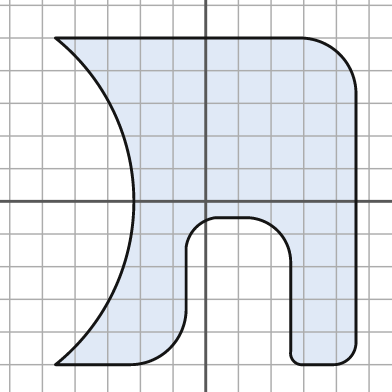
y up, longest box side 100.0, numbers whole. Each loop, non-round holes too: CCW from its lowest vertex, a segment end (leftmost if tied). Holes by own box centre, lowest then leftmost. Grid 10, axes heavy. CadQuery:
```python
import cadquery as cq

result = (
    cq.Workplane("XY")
    .moveTo(-46.0, -50.0)
    .lineTo(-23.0, -50.0)
    .threePointArc((-11.0, -45.0), (-6.0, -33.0))
    .lineTo(-6.0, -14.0)
    .threePointArc((-3.0, -8.0), (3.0, -5.0))
    .lineTo(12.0, -5.0)
    .threePointArc((22.0, -9.0), (26.0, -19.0))
    .lineTo(26.0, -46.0)
    .threePointArc((27.0, -49.0), (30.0, -50.0))
    .lineTo(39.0, -50.0)
    .threePointArc((44.0, -48.0), (46.0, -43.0))
    .lineTo(46.0, 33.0)
    .threePointArc((41.0, 45.0), (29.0, 50.0))
    .lineTo(-46.0, 50.0)
    .threePointArc((-22.0, 0.0), (-46.0, -50.0))
    .close()
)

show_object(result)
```